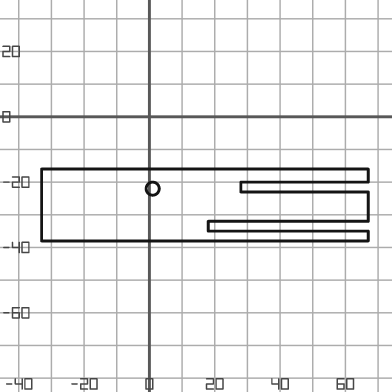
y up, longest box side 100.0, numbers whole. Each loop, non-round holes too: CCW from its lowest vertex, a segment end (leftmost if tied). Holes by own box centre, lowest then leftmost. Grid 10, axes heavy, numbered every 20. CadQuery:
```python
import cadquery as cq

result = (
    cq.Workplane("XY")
    .moveTo(-33.0, -38.0)
    .lineTo(67.0, -38.0)
    .lineTo(67.0, -35.0)
    .lineTo(18.0, -35.0)
    .lineTo(18.0, -32.0)
    .lineTo(67.0, -32.0)
    .lineTo(67.0, -23.0)
    .lineTo(28.0, -23.0)
    .lineTo(28.0, -20.0)
    .lineTo(67.0, -20.0)
    .lineTo(67.0, -16.0)
    .lineTo(-33.0, -16.0)
    .close()
    .moveTo(1.0, -22.0)
    .circle(2.0)
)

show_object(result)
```